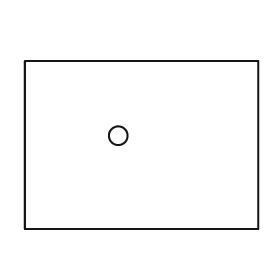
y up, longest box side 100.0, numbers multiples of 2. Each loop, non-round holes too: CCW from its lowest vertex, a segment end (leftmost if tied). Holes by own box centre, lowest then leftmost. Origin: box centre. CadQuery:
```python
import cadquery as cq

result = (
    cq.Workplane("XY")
    .moveTo(-50.0, -36.0)
    .lineTo(50.0, -36.0)
    .lineTo(50.0, 36.0)
    .lineTo(-50.0, 36.0)
    .close()
    .moveTo(-10.0, 4.0)
    .circle(4.0)
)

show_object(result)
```